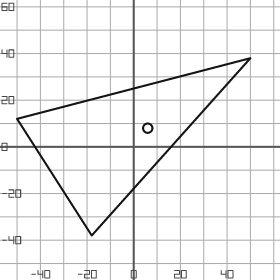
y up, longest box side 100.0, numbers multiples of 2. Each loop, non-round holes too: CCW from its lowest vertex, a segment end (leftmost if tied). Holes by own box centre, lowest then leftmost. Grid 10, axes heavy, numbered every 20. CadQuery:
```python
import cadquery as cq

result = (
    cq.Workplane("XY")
    .moveTo(-18.0, -38.0)
    .lineTo(50.0, 38.0)
    .lineTo(-50.0, 12.0)
    .close()
    .moveTo(6.0, 8.0)
    .circle(2.0)
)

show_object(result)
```